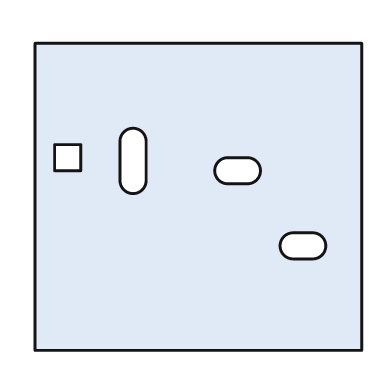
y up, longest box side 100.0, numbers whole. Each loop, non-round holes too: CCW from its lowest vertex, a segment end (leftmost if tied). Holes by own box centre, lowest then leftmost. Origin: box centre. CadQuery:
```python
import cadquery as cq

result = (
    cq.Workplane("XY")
    .moveTo(-50.0, -47.0)
    .lineTo(50.0, -47.0)
    .lineTo(50.0, 47.0)
    .lineTo(-50.0, 47.0)
    .close()
    .moveTo(29.0, -19.0)
    .lineTo(35.0, -19.0)
    .threePointArc((39.0, -15.0), (35.0, -11.0))
    .lineTo(29.0, -11.0)
    .threePointArc((25.0, -15.0), (29.0, -19.0))
    .close()
    .moveTo(9.0, 4.0)
    .lineTo(15.0, 4.0)
    .threePointArc((19.0, 8.0), (15.0, 12.0))
    .lineTo(9.0, 12.0)
    .threePointArc((5.0, 8.0), (9.0, 4.0))
    .close()
    .moveTo(-24.0, 5.0)
    .threePointArc((-20.0, 1.0), (-16.0, 5.0))
    .lineTo(-16.0, 17.0)
    .threePointArc((-20.0, 21.0), (-24.0, 17.0))
    .close()
    .moveTo(-44.0, 8.0)
    .lineTo(-36.0, 8.0)
    .lineTo(-36.0, 16.0)
    .lineTo(-44.0, 16.0)
    .close()
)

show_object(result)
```